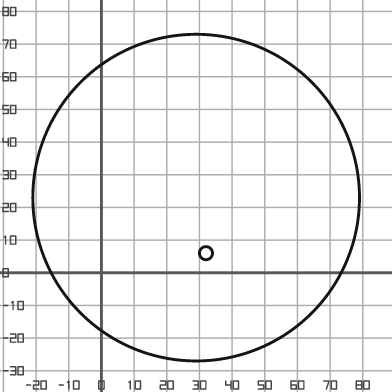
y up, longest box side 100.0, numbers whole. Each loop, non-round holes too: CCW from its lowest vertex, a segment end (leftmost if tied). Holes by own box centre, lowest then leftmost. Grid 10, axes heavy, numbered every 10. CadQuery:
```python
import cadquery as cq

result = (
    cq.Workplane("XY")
    .moveTo(29.0, 23.0)
    .circle(50.0)
    .moveTo(32.0, 6.0)
    .circle(2.0)
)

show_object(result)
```